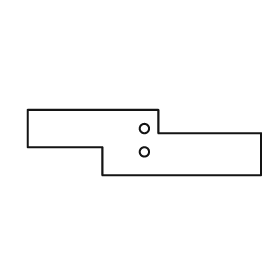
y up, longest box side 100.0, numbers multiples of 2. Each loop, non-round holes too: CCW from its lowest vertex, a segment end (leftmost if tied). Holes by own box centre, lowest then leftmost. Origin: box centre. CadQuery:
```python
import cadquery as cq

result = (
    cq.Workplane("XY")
    .moveTo(-18.0, -14.0)
    .lineTo(50.0, -14.0)
    .lineTo(50.0, 4.0)
    .lineTo(6.0, 4.0)
    .lineTo(6.0, 14.0)
    .lineTo(-50.0, 14.0)
    .lineTo(-50.0, -2.0)
    .lineTo(-18.0, -2.0)
    .close()
    .moveTo(0.0, -4.0)
    .circle(2.0)
    .moveTo(0.0, 6.0)
    .circle(2.0)
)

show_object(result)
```